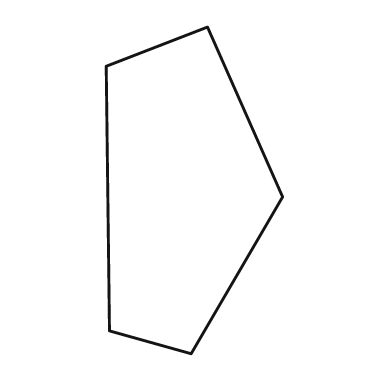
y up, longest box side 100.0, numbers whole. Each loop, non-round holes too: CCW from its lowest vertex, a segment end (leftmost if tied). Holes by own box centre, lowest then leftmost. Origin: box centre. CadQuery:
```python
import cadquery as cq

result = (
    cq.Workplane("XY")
    .moveTo(-1.0, -50.0)
    .lineTo(27.0, -2.0)
    .lineTo(4.0, 50.0)
    .lineTo(-27.0, 38.0)
    .lineTo(-26.0, -43.0)
    .close()
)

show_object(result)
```